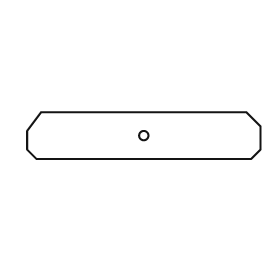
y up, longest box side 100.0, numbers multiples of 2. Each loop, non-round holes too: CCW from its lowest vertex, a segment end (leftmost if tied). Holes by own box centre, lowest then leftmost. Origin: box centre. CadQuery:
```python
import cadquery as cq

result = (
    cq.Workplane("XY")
    .moveTo(-46.0, -10.0)
    .lineTo(46.0, -10.0)
    .lineTo(50.0, -6.0)
    .lineTo(50.0, 4.0)
    .lineTo(44.0, 10.0)
    .lineTo(-44.0, 10.0)
    .lineTo(-50.0, 2.0)
    .lineTo(-50.0, -6.0)
    .close()
    .moveTo(0.0, 0.0)
    .circle(2.0)
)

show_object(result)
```